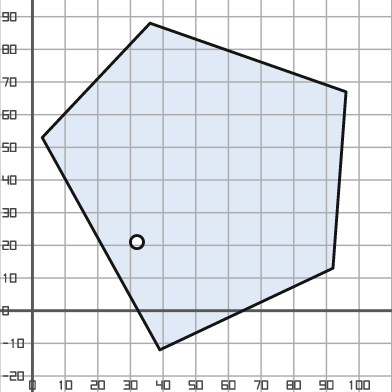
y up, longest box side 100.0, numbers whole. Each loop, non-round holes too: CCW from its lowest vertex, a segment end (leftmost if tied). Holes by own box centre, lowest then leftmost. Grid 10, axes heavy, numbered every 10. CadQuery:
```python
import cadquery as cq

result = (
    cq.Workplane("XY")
    .moveTo(39.0, -12.0)
    .lineTo(92.0, 13.0)
    .lineTo(96.0, 67.0)
    .lineTo(36.0, 88.0)
    .lineTo(3.0, 53.0)
    .close()
    .moveTo(32.0, 21.0)
    .circle(2.0)
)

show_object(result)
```